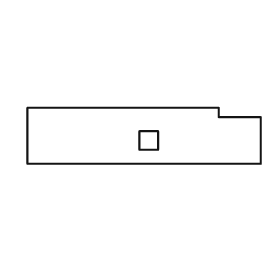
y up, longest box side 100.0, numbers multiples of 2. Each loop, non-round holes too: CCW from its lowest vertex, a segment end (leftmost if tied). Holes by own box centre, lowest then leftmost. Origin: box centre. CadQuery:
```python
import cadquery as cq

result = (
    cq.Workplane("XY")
    .moveTo(-50.0, -12.0)
    .lineTo(50.0, -12.0)
    .lineTo(50.0, 8.0)
    .lineTo(32.0, 8.0)
    .lineTo(32.0, 12.0)
    .lineTo(-50.0, 12.0)
    .close()
    .moveTo(-2.0, -6.0)
    .lineTo(6.0, -6.0)
    .lineTo(6.0, 2.0)
    .lineTo(-2.0, 2.0)
    .close()
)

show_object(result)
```